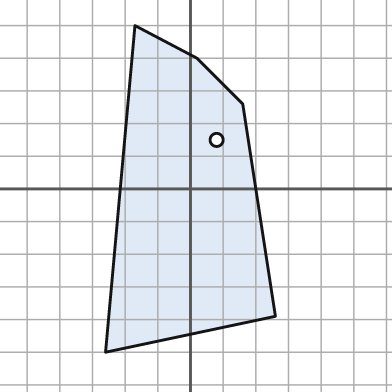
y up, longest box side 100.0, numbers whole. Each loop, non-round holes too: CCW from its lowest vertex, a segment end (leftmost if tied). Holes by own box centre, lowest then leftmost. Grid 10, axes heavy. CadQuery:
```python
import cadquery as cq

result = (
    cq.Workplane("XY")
    .moveTo(-26.0, -50.0)
    .lineTo(26.0, -39.0)
    .lineTo(16.0, 26.0)
    .lineTo(2.0, 40.0)
    .lineTo(-17.0, 50.0)
    .close()
    .moveTo(8.0, 15.0)
    .circle(2.0)
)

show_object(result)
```